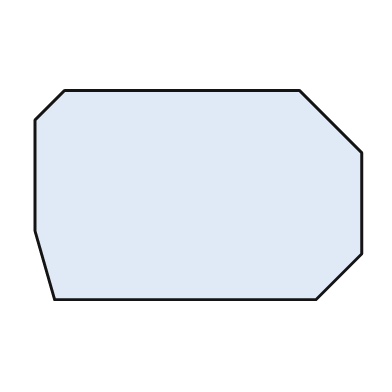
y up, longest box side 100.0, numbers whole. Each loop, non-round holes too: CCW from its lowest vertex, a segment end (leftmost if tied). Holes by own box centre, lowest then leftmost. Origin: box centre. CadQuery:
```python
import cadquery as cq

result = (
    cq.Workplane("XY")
    .moveTo(-44.0, -32.0)
    .lineTo(36.0, -32.0)
    .lineTo(50.0, -18.0)
    .lineTo(50.0, 13.0)
    .lineTo(31.0, 32.0)
    .lineTo(-41.0, 32.0)
    .lineTo(-50.0, 23.0)
    .lineTo(-50.0, -11.0)
    .close()
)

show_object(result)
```